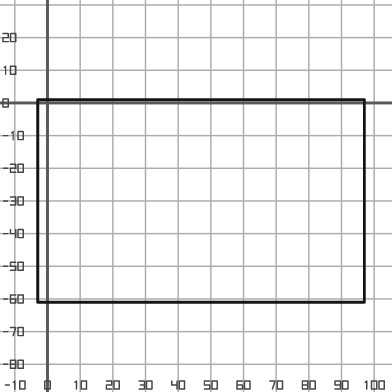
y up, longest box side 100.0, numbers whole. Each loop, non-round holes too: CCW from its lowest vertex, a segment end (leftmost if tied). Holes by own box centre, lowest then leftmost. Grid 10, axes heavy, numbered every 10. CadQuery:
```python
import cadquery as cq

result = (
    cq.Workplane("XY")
    .moveTo(-3.0, -61.0)
    .lineTo(97.0, -61.0)
    .lineTo(97.0, 1.0)
    .lineTo(-3.0, 1.0)
    .close()
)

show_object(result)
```